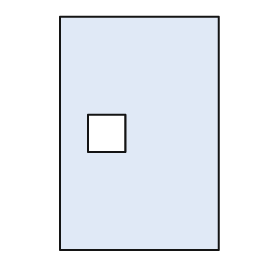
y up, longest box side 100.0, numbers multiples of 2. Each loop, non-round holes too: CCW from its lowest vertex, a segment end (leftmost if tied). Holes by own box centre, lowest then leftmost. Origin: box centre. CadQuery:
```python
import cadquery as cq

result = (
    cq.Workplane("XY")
    .moveTo(-34.0, -50.0)
    .lineTo(34.0, -50.0)
    .lineTo(34.0, 50.0)
    .lineTo(-34.0, 50.0)
    .close()
    .moveTo(-22.0, -8.0)
    .lineTo(-6.0, -8.0)
    .lineTo(-6.0, 8.0)
    .lineTo(-22.0, 8.0)
    .close()
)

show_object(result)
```